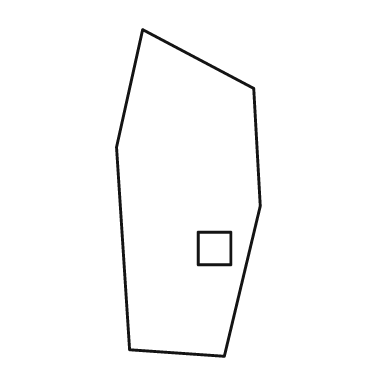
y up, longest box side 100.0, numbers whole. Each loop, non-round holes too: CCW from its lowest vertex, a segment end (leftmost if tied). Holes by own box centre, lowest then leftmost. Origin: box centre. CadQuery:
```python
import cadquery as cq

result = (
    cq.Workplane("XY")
    .moveTo(11.0, -50.0)
    .lineTo(22.0, -4.0)
    .lineTo(20.0, 32.0)
    .lineTo(-14.0, 50.0)
    .lineTo(-22.0, 14.0)
    .lineTo(-18.0, -48.0)
    .close()
    .moveTo(3.0, -22.0)
    .lineTo(13.0, -22.0)
    .lineTo(13.0, -12.0)
    .lineTo(3.0, -12.0)
    .close()
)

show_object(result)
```